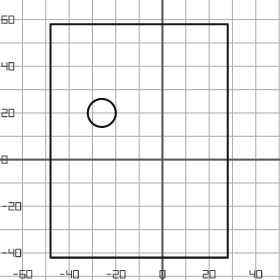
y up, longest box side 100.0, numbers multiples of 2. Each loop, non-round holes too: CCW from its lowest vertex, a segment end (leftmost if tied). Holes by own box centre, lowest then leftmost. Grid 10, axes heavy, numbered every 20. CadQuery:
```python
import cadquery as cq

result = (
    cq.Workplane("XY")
    .moveTo(-48.0, -42.0)
    .lineTo(28.0, -42.0)
    .lineTo(28.0, 58.0)
    .lineTo(-48.0, 58.0)
    .close()
    .moveTo(-26.0, 20.0)
    .circle(6.0)
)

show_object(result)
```